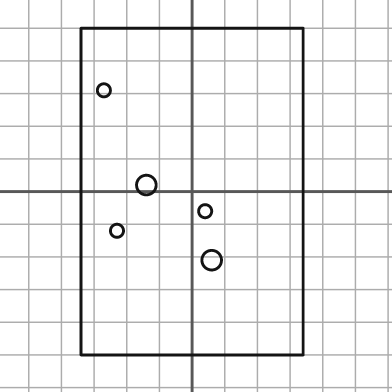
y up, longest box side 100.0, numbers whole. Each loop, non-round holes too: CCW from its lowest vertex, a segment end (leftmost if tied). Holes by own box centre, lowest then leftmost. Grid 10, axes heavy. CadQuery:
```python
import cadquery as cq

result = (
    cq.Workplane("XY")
    .moveTo(-34.0, -50.0)
    .lineTo(34.0, -50.0)
    .lineTo(34.0, 50.0)
    .lineTo(-34.0, 50.0)
    .close()
    .moveTo(6.0, -21.0)
    .circle(3.0)
    .moveTo(-23.0, -12.0)
    .circle(2.0)
    .moveTo(4.0, -6.0)
    .circle(2.0)
    .moveTo(-14.0, 2.0)
    .circle(3.0)
    .moveTo(-27.0, 31.0)
    .circle(2.0)
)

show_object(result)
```